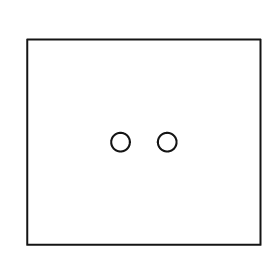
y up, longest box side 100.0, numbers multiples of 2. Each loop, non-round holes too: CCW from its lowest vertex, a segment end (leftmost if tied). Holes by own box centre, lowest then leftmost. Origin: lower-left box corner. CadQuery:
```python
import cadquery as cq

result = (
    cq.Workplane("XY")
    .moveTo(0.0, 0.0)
    .lineTo(100.0, 0.0)
    .lineTo(100.0, 88.0)
    .lineTo(0.0, 88.0)
    .close()
    .moveTo(40.0, 44.0)
    .circle(4.0)
    .moveTo(60.0, 44.0)
    .circle(4.0)
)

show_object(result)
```